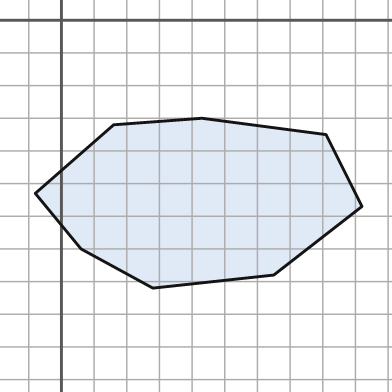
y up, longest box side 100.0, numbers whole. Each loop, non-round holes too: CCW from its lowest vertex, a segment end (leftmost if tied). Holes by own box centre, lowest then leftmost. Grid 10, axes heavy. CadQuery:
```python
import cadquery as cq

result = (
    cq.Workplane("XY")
    .moveTo(28.0, -82.0)
    .lineTo(65.0, -78.0)
    .lineTo(92.0, -57.0)
    .lineTo(81.0, -35.0)
    .lineTo(43.0, -30.0)
    .lineTo(16.0, -32.0)
    .lineTo(-8.0, -53.0)
    .lineTo(6.0, -70.0)
    .close()
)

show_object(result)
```